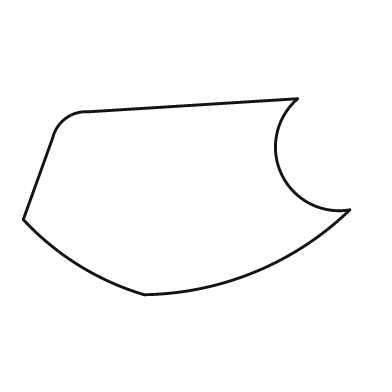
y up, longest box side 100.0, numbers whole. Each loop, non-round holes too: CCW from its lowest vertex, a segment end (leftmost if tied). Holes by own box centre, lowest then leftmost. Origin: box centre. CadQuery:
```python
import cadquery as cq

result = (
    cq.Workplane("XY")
    .moveTo(-13.0, -30.0)
    .threePointArc((21.0, -23.0), (50.0, -4.0))
    .threePointArc((29.0, 7.0), (34.0, 30.0))
    .lineTo(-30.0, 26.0)
    .threePointArc((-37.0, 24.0), (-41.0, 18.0))
    .lineTo(-50.0, -7.0)
    .threePointArc((-33.0, -21.0), (-13.0, -30.0))
    .close()
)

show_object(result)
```